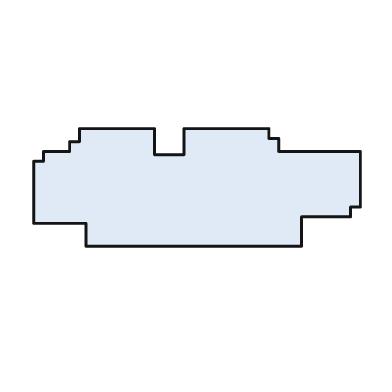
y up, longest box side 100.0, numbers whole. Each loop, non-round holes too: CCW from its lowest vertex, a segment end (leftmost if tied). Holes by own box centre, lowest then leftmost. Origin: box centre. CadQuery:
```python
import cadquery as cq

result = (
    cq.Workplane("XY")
    .moveTo(-34.0, -18.0)
    .lineTo(32.0, -18.0)
    .lineTo(32.0, -9.0)
    .lineTo(47.0, -9.0)
    .lineTo(47.0, -6.0)
    .lineTo(50.0, -6.0)
    .lineTo(50.0, 11.0)
    .lineTo(25.0, 11.0)
    .lineTo(25.0, 15.0)
    .lineTo(22.0, 15.0)
    .lineTo(22.0, 18.0)
    .lineTo(-4.0, 18.0)
    .lineTo(-4.0, 10.0)
    .lineTo(-13.0, 10.0)
    .lineTo(-13.0, 18.0)
    .lineTo(-36.0, 18.0)
    .lineTo(-36.0, 14.0)
    .lineTo(-39.0, 14.0)
    .lineTo(-39.0, 11.0)
    .lineTo(-47.0, 11.0)
    .lineTo(-47.0, 8.0)
    .lineTo(-50.0, 8.0)
    .lineTo(-50.0, -11.0)
    .lineTo(-34.0, -11.0)
    .close()
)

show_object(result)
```